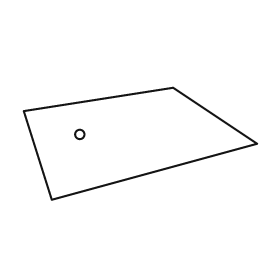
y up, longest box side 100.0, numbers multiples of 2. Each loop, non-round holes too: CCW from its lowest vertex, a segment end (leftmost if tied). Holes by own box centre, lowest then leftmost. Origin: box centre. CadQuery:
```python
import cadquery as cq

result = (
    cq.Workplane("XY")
    .moveTo(-38.0, -24.0)
    .lineTo(50.0, 0.0)
    .lineTo(14.0, 24.0)
    .lineTo(-50.0, 14.0)
    .close()
    .moveTo(-26.0, 4.0)
    .circle(2.0)
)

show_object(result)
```